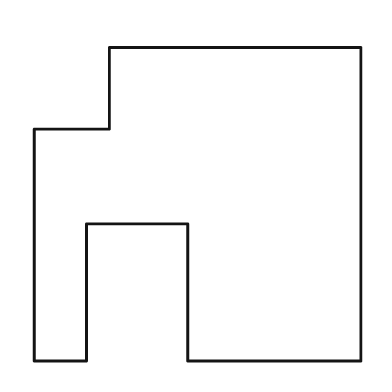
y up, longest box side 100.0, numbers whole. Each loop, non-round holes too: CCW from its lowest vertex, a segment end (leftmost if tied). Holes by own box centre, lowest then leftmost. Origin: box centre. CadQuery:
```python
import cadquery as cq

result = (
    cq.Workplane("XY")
    .moveTo(-50.0, -48.0)
    .lineTo(-34.0, -48.0)
    .lineTo(-34.0, -6.0)
    .lineTo(-3.0, -6.0)
    .lineTo(-3.0, -48.0)
    .lineTo(50.0, -48.0)
    .lineTo(50.0, 48.0)
    .lineTo(-27.0, 48.0)
    .lineTo(-27.0, 23.0)
    .lineTo(-50.0, 23.0)
    .close()
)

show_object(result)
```